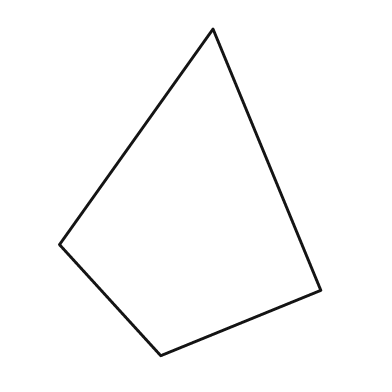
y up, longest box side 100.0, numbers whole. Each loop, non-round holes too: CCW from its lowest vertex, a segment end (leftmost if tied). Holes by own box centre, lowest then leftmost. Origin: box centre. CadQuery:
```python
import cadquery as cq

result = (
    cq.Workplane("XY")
    .moveTo(-9.0, -50.0)
    .lineTo(40.0, -30.0)
    .lineTo(7.0, 50.0)
    .lineTo(-40.0, -16.0)
    .close()
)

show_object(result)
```